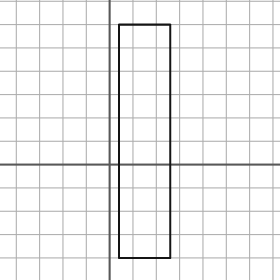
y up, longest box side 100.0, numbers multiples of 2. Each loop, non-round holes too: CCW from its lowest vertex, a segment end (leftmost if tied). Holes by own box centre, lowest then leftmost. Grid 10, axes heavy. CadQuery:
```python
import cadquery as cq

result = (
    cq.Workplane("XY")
    .moveTo(4.0, -40.0)
    .lineTo(26.0, -40.0)
    .lineTo(26.0, 60.0)
    .lineTo(4.0, 60.0)
    .close()
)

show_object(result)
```